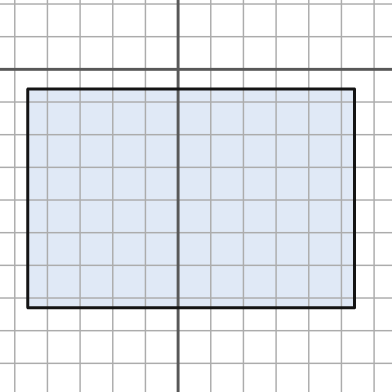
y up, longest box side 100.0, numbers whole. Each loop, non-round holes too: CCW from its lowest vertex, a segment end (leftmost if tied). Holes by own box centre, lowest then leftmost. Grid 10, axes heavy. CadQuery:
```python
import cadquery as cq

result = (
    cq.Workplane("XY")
    .moveTo(-46.0, -73.0)
    .lineTo(54.0, -73.0)
    .lineTo(54.0, -6.0)
    .lineTo(-46.0, -6.0)
    .close()
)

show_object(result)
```